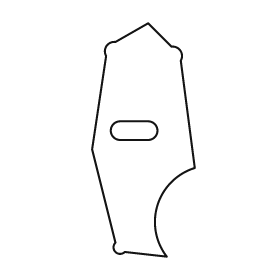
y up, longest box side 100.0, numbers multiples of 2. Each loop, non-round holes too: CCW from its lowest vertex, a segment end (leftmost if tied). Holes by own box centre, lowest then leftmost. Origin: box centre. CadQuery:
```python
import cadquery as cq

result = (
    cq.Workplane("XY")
    .moveTo(10.0, -50.0)
    .threePointArc((6.0, -28.0), (22.0, -12.0))
    .lineTo(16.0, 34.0)
    .threePointArc((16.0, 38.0), (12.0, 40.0))
    .lineTo(2.0, 50.0)
    .lineTo(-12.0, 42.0)
    .threePointArc((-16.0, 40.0), (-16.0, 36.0))
    .lineTo(-22.0, -4.0)
    .lineTo(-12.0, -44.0)
    .threePointArc((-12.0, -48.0), (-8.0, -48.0))
    .close()
    .moveTo(-10.0, 0.0)
    .lineTo(2.0, 0.0)
    .threePointArc((6.0, 4.0), (2.0, 8.0))
    .lineTo(-10.0, 8.0)
    .threePointArc((-14.0, 4.0), (-10.0, 0.0))
    .close()
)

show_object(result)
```